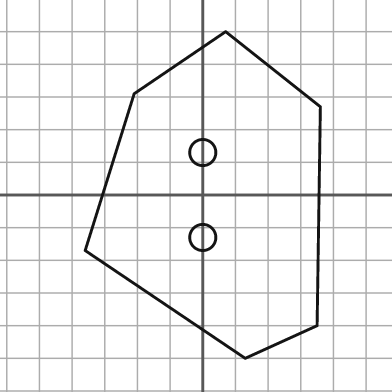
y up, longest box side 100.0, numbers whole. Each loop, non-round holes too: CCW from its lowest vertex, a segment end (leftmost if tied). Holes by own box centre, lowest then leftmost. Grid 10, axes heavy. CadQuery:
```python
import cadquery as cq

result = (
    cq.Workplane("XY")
    .moveTo(13.0, -50.0)
    .lineTo(35.0, -40.0)
    .lineTo(36.0, 27.0)
    .lineTo(7.0, 50.0)
    .lineTo(-21.0, 31.0)
    .lineTo(-36.0, -17.0)
    .close()
    .moveTo(0.0, -13.0)
    .circle(4.0)
    .moveTo(0.0, 13.0)
    .circle(4.0)
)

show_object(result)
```